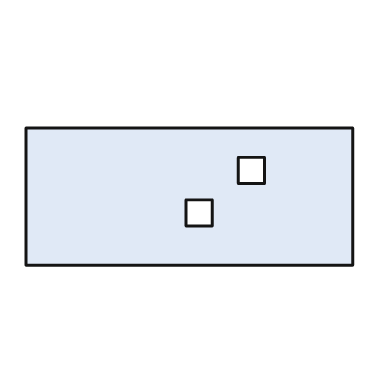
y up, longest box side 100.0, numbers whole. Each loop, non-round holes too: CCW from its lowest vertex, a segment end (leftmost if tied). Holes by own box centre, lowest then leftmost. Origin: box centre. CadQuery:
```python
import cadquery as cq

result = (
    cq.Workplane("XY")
    .moveTo(-50.0, -21.0)
    .lineTo(50.0, -21.0)
    .lineTo(50.0, 21.0)
    .lineTo(-50.0, 21.0)
    .close()
    .moveTo(-1.0, -9.0)
    .lineTo(7.0, -9.0)
    .lineTo(7.0, -1.0)
    .lineTo(-1.0, -1.0)
    .close()
    .moveTo(15.0, 4.0)
    .lineTo(23.0, 4.0)
    .lineTo(23.0, 12.0)
    .lineTo(15.0, 12.0)
    .close()
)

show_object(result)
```